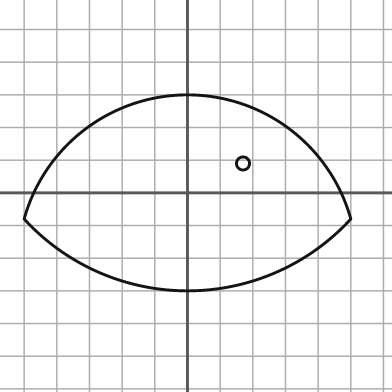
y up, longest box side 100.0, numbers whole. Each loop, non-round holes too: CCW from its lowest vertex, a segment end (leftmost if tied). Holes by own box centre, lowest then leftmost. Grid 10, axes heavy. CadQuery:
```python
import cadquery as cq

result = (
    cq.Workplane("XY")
    .moveTo(-50.0, -8.0)
    .threePointArc((0.0, -30.0), (50.0, -8.0))
    .threePointArc((0.0, 30.0), (-50.0, -8.0))
    .close()
    .moveTo(17.0, 9.0)
    .circle(2.0)
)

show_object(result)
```